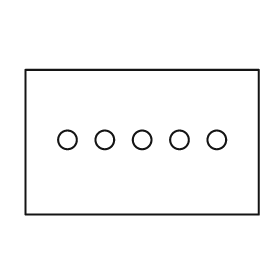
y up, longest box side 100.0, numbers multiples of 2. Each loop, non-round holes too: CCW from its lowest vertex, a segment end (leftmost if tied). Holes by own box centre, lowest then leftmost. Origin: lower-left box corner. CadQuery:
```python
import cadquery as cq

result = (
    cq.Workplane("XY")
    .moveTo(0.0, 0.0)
    .lineTo(100.0, 0.0)
    .lineTo(100.0, 62.0)
    .lineTo(0.0, 62.0)
    .close()
    .moveTo(18.0, 32.0)
    .circle(4.0)
    .moveTo(34.0, 32.0)
    .circle(4.0)
    .moveTo(50.0, 32.0)
    .circle(4.0)
    .moveTo(66.0, 32.0)
    .circle(4.0)
    .moveTo(82.0, 32.0)
    .circle(4.0)
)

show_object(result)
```